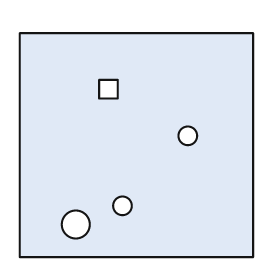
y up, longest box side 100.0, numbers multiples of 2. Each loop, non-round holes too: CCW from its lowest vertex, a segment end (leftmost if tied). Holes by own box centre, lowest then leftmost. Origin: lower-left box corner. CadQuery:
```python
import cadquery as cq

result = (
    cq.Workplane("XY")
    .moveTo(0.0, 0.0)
    .lineTo(100.0, 0.0)
    .lineTo(100.0, 96.0)
    .lineTo(0.0, 96.0)
    .close()
    .moveTo(24.0, 14.0)
    .circle(6.0)
    .moveTo(44.0, 22.0)
    .circle(4.0)
    .moveTo(72.0, 52.0)
    .circle(4.0)
    .moveTo(34.0, 68.0)
    .lineTo(42.0, 68.0)
    .lineTo(42.0, 76.0)
    .lineTo(34.0, 76.0)
    .close()
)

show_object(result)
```